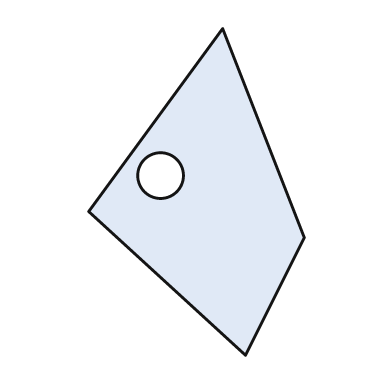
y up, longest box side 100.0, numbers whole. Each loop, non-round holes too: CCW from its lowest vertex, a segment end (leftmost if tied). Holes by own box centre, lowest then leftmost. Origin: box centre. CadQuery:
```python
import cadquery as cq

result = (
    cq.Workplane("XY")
    .moveTo(15.0, -50.0)
    .lineTo(33.0, -14.0)
    .lineTo(8.0, 50.0)
    .lineTo(-33.0, -6.0)
    .close()
    .moveTo(-11.0, 5.0)
    .circle(7.0)
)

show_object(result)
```